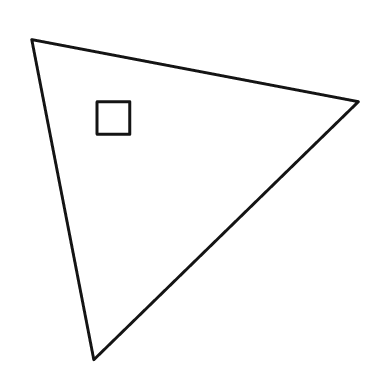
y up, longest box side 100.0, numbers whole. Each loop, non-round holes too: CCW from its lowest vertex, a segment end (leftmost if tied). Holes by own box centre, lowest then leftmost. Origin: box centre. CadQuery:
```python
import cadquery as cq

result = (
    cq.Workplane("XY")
    .moveTo(-31.0, -49.0)
    .lineTo(50.0, 30.0)
    .lineTo(-50.0, 49.0)
    .close()
    .moveTo(-30.0, 20.0)
    .lineTo(-20.0, 20.0)
    .lineTo(-20.0, 30.0)
    .lineTo(-30.0, 30.0)
    .close()
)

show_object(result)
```